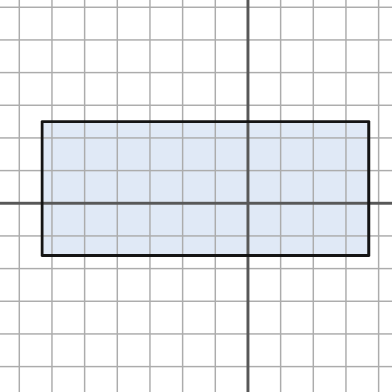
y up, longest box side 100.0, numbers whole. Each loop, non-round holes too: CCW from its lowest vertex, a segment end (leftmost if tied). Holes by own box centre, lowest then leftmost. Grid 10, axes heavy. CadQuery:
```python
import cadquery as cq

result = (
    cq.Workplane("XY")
    .moveTo(-63.0, -16.0)
    .lineTo(37.0, -16.0)
    .lineTo(37.0, 25.0)
    .lineTo(-63.0, 25.0)
    .close()
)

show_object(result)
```